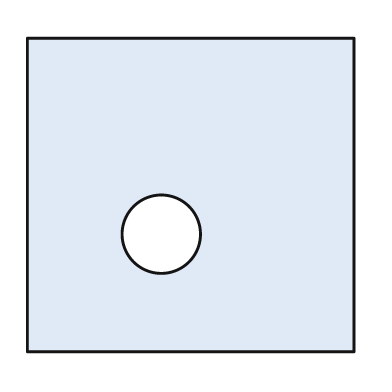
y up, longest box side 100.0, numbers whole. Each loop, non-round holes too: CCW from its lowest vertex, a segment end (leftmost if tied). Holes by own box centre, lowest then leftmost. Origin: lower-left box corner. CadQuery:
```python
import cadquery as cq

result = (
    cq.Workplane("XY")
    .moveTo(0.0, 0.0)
    .lineTo(100.0, 0.0)
    .lineTo(100.0, 96.0)
    .lineTo(0.0, 96.0)
    .close()
    .moveTo(41.0, 36.0)
    .circle(12.0)
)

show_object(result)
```